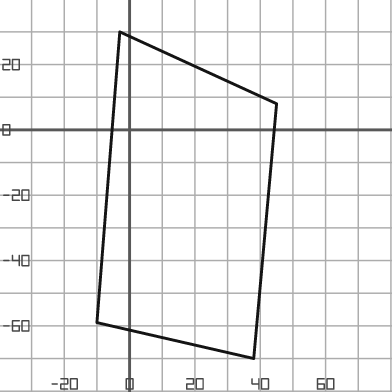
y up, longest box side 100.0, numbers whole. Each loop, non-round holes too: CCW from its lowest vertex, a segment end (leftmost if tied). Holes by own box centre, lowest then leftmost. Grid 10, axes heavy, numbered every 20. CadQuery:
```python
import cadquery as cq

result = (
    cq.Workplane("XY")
    .moveTo(38.0, -70.0)
    .lineTo(45.0, 8.0)
    .lineTo(-3.0, 30.0)
    .lineTo(-10.0, -59.0)
    .close()
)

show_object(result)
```